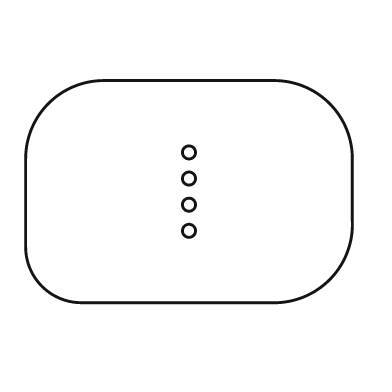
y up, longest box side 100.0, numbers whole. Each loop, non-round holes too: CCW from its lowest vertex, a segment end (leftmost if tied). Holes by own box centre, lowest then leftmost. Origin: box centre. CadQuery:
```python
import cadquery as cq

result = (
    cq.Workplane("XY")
    .moveTo(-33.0, -34.0)
    .lineTo(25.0, -34.0)
    .threePointArc((43.0, -27.0), (50.0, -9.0))
    .lineTo(50.0, 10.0)
    .threePointArc((43.0, 27.0), (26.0, 34.0))
    .lineTo(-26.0, 34.0)
    .threePointArc((-43.0, 27.0), (-50.0, 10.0))
    .lineTo(-50.0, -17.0)
    .threePointArc((-45.0, -29.0), (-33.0, -34.0))
    .close()
    .moveTo(0.0, -12.0)
    .circle(2.0)
    .moveTo(0.0, -4.0)
    .circle(2.0)
    .moveTo(0.0, 4.0)
    .circle(2.0)
    .moveTo(0.0, 12.0)
    .circle(2.0)
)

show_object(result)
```